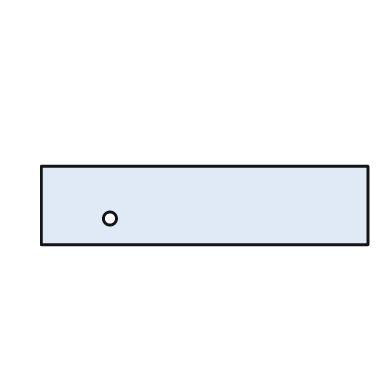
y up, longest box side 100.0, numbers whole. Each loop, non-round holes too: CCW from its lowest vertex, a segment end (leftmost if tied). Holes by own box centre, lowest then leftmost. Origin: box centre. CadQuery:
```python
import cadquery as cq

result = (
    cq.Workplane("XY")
    .moveTo(-50.0, -12.0)
    .lineTo(50.0, -12.0)
    .lineTo(50.0, 12.0)
    .lineTo(-50.0, 12.0)
    .close()
    .moveTo(-29.0, -4.0)
    .circle(2.0)
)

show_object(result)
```